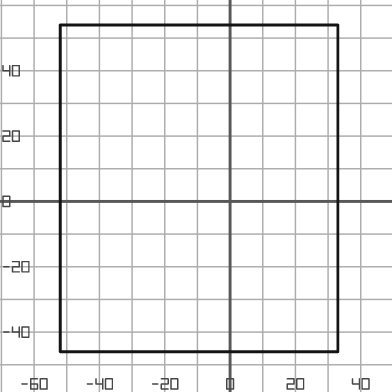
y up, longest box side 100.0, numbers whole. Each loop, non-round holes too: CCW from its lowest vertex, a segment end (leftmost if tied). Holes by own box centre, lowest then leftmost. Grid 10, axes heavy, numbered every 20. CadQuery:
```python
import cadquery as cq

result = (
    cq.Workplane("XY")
    .moveTo(-52.0, -46.0)
    .lineTo(33.0, -46.0)
    .lineTo(33.0, 54.0)
    .lineTo(-52.0, 54.0)
    .close()
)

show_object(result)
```